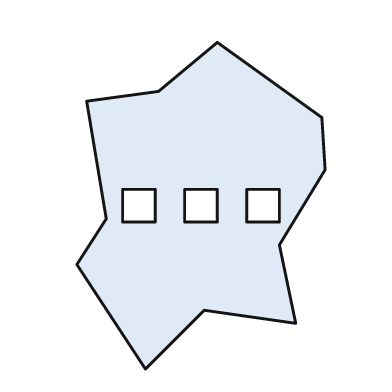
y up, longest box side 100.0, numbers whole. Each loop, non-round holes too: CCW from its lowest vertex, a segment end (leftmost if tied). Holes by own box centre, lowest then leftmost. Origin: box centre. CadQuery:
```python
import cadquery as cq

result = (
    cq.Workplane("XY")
    .moveTo(-17.0, -50.0)
    .lineTo(1.0, -32.0)
    .lineTo(29.0, -36.0)
    .lineTo(24.0, -12.0)
    .lineTo(38.0, 11.0)
    .lineTo(37.0, 27.0)
    .lineTo(5.0, 50.0)
    .lineTo(-13.0, 35.0)
    .lineTo(-35.0, 32.0)
    .lineTo(-29.0, -4.0)
    .lineTo(-38.0, -18.0)
    .close()
    .moveTo(-24.0, -5.0)
    .lineTo(-14.0, -5.0)
    .lineTo(-14.0, 5.0)
    .lineTo(-24.0, 5.0)
    .close()
    .moveTo(-5.0, -5.0)
    .lineTo(5.0, -5.0)
    .lineTo(5.0, 5.0)
    .lineTo(-5.0, 5.0)
    .close()
    .moveTo(14.0, -5.0)
    .lineTo(24.0, -5.0)
    .lineTo(24.0, 5.0)
    .lineTo(14.0, 5.0)
    .close()
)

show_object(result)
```